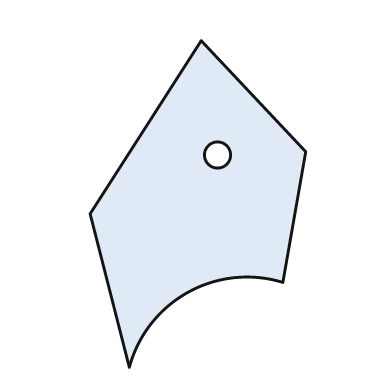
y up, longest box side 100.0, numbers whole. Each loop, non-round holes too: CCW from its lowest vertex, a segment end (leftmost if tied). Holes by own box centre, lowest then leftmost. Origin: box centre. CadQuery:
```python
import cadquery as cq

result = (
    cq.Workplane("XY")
    .moveTo(-21.0, -50.0)
    .threePointArc((-3.0, -27.0), (26.0, -24.0))
    .lineTo(33.0, 16.0)
    .lineTo(1.0, 50.0)
    .lineTo(-33.0, -3.0)
    .close()
    .moveTo(6.0, 15.0)
    .circle(4.0)
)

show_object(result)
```